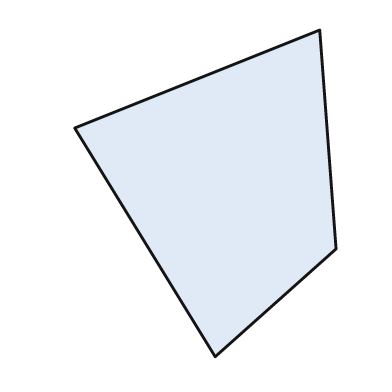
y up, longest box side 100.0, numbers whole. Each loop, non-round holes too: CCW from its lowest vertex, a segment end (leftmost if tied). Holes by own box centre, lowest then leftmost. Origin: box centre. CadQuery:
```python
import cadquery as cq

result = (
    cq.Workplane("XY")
    .moveTo(3.0, -50.0)
    .lineTo(40.0, -17.0)
    .lineTo(35.0, 50.0)
    .lineTo(-40.0, 20.0)
    .close()
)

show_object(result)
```